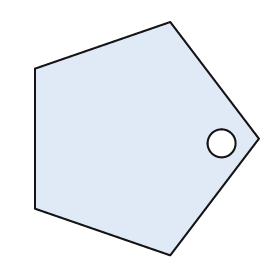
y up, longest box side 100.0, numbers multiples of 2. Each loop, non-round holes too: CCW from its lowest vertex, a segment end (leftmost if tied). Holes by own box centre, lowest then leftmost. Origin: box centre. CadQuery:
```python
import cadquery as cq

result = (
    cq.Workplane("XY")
    .moveTo(10.0, -50.0)
    .lineTo(48.0, 0.0)
    .lineTo(10.0, 50.0)
    .lineTo(-48.0, 30.0)
    .lineTo(-48.0, -30.0)
    .close()
    .moveTo(32.0, -2.0)
    .circle(6.0)
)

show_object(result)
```